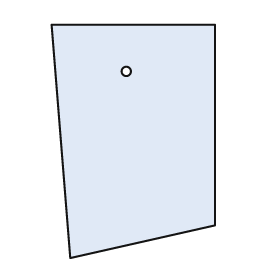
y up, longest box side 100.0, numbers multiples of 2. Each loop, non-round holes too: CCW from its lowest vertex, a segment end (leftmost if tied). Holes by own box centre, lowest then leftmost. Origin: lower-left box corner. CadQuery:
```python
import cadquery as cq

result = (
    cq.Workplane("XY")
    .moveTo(8.0, 0.0)
    .lineTo(70.0, 14.0)
    .lineTo(70.0, 100.0)
    .lineTo(0.0, 100.0)
    .close()
    .moveTo(32.0, 80.0)
    .circle(2.0)
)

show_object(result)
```